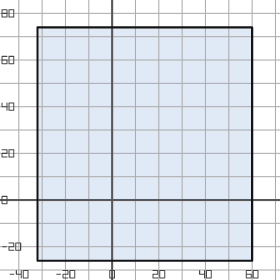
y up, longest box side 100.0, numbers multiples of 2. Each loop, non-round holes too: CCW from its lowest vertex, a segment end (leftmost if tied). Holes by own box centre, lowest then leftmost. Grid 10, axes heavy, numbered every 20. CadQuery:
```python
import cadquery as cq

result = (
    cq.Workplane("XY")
    .moveTo(-32.0, -26.0)
    .lineTo(60.0, -26.0)
    .lineTo(60.0, 74.0)
    .lineTo(-32.0, 74.0)
    .close()
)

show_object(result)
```